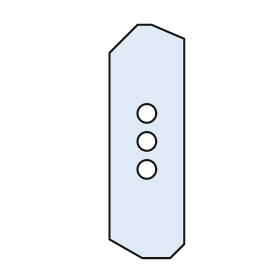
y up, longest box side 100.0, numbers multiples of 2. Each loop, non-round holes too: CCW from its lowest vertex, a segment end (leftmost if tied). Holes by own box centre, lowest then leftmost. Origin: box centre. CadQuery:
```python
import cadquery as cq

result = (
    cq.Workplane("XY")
    .moveTo(-2.0, -50.0)
    .lineTo(10.0, -50.0)
    .lineTo(16.0, -44.0)
    .lineTo(16.0, 44.0)
    .lineTo(2.0, 50.0)
    .lineTo(-4.0, 50.0)
    .lineTo(-16.0, 38.0)
    .lineTo(-16.0, -42.0)
    .close()
    .moveTo(0.0, -12.0)
    .circle(4.0)
    .moveTo(0.0, 0.0)
    .circle(4.0)
    .moveTo(0.0, 12.0)
    .circle(4.0)
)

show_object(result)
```